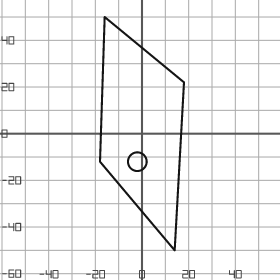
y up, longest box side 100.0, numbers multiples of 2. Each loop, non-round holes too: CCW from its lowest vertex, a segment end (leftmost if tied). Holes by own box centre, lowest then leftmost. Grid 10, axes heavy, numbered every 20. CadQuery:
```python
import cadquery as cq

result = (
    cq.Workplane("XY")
    .moveTo(14.0, -50.0)
    .lineTo(18.0, 22.0)
    .lineTo(-16.0, 50.0)
    .lineTo(-18.0, -12.0)
    .close()
    .moveTo(-2.0, -12.0)
    .circle(4.0)
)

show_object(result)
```